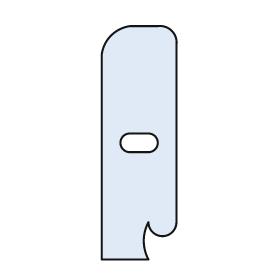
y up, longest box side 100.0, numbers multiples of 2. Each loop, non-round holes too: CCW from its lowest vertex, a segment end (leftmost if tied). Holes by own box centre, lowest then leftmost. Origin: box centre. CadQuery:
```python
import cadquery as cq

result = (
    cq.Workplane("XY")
    .moveTo(-16.0, -50.0)
    .lineTo(4.0, -50.0)
    .threePointArc((2.0, -42.0), (4.0, -34.0))
    .threePointArc((10.0, -40.0), (16.0, -34.0))
    .lineTo(16.0, 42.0)
    .threePointArc((14.0, 48.0), (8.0, 50.0))
    .lineTo(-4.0, 50.0)
    .threePointArc((-12.0, 46.0), (-16.0, 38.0))
    .close()
    .moveTo(-4.0, -4.0)
    .lineTo(4.0, -4.0)
    .threePointArc((8.0, 0.0), (4.0, 4.0))
    .lineTo(-4.0, 4.0)
    .threePointArc((-8.0, 0.0), (-4.0, -4.0))
    .close()
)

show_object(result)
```